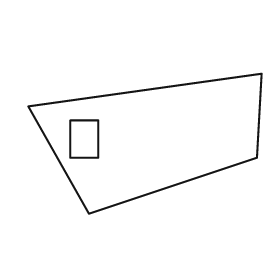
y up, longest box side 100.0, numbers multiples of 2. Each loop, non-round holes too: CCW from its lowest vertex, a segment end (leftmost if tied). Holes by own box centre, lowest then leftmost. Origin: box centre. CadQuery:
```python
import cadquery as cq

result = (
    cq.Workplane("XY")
    .moveTo(-24.0, -30.0)
    .lineTo(48.0, -6.0)
    .lineTo(50.0, 30.0)
    .lineTo(-50.0, 16.0)
    .close()
    .moveTo(-32.0, -6.0)
    .lineTo(-20.0, -6.0)
    .lineTo(-20.0, 10.0)
    .lineTo(-32.0, 10.0)
    .close()
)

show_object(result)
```